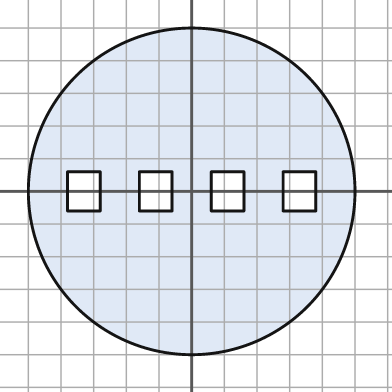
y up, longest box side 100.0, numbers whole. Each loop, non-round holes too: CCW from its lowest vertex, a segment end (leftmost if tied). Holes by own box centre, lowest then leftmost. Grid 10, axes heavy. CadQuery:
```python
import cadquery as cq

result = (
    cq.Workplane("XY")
    .moveTo(0.0, 0.0)
    .circle(50.0)
    .moveTo(-38.0, -6.0)
    .lineTo(-28.0, -6.0)
    .lineTo(-28.0, 6.0)
    .lineTo(-38.0, 6.0)
    .close()
    .moveTo(-16.0, -6.0)
    .lineTo(-6.0, -6.0)
    .lineTo(-6.0, 6.0)
    .lineTo(-16.0, 6.0)
    .close()
    .moveTo(6.0, -6.0)
    .lineTo(16.0, -6.0)
    .lineTo(16.0, 6.0)
    .lineTo(6.0, 6.0)
    .close()
    .moveTo(28.0, -6.0)
    .lineTo(38.0, -6.0)
    .lineTo(38.0, 6.0)
    .lineTo(28.0, 6.0)
    .close()
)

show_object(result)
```